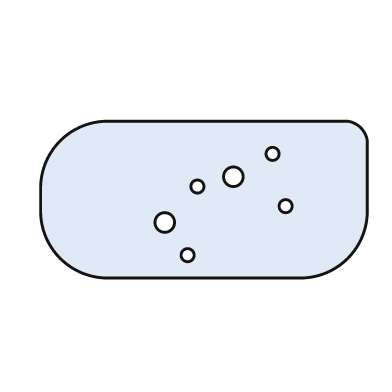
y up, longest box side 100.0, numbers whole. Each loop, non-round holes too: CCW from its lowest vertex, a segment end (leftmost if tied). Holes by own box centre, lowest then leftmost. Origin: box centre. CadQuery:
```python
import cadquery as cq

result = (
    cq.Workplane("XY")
    .moveTo(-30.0, -24.0)
    .lineTo(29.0, -24.0)
    .threePointArc((44.0, -18.0), (50.0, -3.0))
    .lineTo(50.0, 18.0)
    .threePointArc((48.0, 22.0), (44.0, 24.0))
    .lineTo(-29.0, 24.0)
    .threePointArc((-44.0, 18.0), (-50.0, 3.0))
    .lineTo(-50.0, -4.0)
    .threePointArc((-44.0, -18.0), (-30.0, -24.0))
    .close()
    .moveTo(-5.0, -17.0)
    .circle(2.0)
    .moveTo(-12.0, -7.0)
    .circle(3.0)
    .moveTo(25.0, -2.0)
    .circle(2.0)
    .moveTo(-2.0, 4.0)
    .circle(2.0)
    .moveTo(9.0, 7.0)
    .circle(3.0)
    .moveTo(21.0, 14.0)
    .circle(2.0)
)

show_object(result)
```